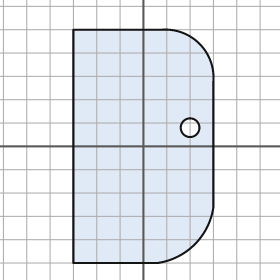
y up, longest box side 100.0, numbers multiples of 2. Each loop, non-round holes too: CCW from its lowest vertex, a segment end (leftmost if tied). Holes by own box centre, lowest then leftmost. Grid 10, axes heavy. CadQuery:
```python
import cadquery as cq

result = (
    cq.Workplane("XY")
    .moveTo(-30.0, -50.0)
    .lineTo(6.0, -50.0)
    .threePointArc((22.0, -42.0), (30.0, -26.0))
    .lineTo(30.0, 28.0)
    .threePointArc((24.0, 44.0), (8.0, 50.0))
    .lineTo(-30.0, 50.0)
    .close()
    .moveTo(20.0, 8.0)
    .circle(4.0)
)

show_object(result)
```